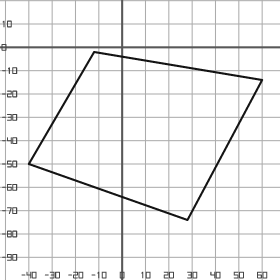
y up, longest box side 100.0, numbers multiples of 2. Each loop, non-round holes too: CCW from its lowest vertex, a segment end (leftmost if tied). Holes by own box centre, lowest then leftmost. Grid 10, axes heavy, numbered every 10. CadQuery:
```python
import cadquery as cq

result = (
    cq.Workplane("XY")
    .moveTo(28.0, -74.0)
    .lineTo(60.0, -14.0)
    .lineTo(-12.0, -2.0)
    .lineTo(-40.0, -50.0)
    .close()
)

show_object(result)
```